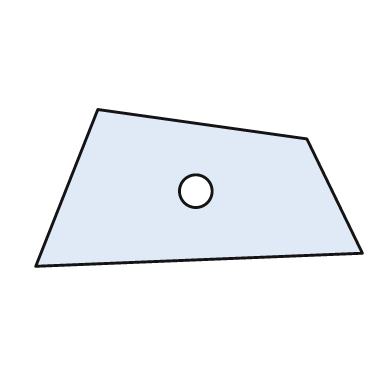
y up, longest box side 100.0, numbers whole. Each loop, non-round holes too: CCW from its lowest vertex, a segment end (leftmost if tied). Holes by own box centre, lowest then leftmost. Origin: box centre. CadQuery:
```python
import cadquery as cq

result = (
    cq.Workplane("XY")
    .moveTo(-50.0, -24.0)
    .lineTo(50.0, -20.0)
    .lineTo(33.0, 15.0)
    .lineTo(-31.0, 24.0)
    .close()
    .moveTo(-1.0, -1.0)
    .circle(5.0)
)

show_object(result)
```